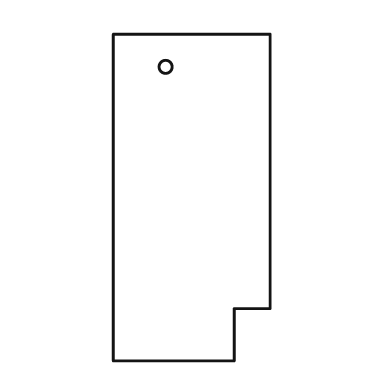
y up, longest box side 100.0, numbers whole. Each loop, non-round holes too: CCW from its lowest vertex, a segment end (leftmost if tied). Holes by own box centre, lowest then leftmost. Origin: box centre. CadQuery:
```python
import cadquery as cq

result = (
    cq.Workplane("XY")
    .moveTo(-24.0, -50.0)
    .lineTo(13.0, -50.0)
    .lineTo(13.0, -34.0)
    .lineTo(24.0, -34.0)
    .lineTo(24.0, 50.0)
    .lineTo(-24.0, 50.0)
    .close()
    .moveTo(-8.0, 40.0)
    .circle(2.0)
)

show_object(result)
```